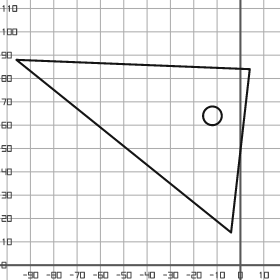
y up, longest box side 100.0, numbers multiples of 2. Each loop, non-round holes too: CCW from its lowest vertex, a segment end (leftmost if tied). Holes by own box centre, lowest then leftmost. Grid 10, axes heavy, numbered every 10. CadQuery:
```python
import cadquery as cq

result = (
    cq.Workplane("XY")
    .moveTo(-4.0, 14.0)
    .lineTo(4.0, 84.0)
    .lineTo(-96.0, 88.0)
    .close()
    .moveTo(-12.0, 64.0)
    .circle(4.0)
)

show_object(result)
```